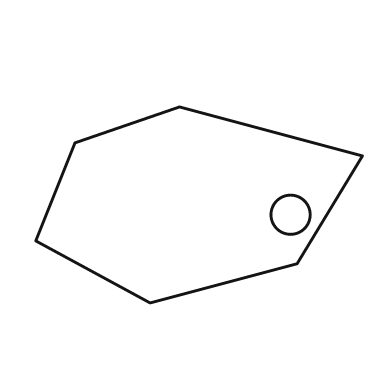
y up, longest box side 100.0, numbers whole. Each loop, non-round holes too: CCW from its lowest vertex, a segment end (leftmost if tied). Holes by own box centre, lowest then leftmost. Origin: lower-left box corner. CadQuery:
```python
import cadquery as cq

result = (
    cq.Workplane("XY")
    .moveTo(35.0, 0.0)
    .lineTo(80.0, 12.0)
    .lineTo(100.0, 45.0)
    .lineTo(44.0, 60.0)
    .lineTo(12.0, 49.0)
    .lineTo(0.0, 19.0)
    .close()
    .moveTo(78.0, 27.0)
    .circle(6.0)
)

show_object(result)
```